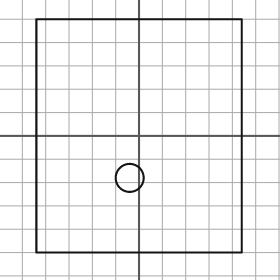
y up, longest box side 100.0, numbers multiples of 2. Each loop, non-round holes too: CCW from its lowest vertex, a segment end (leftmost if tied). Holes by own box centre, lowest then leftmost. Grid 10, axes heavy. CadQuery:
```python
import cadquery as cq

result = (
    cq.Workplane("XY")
    .moveTo(-44.0, -50.0)
    .lineTo(44.0, -50.0)
    .lineTo(44.0, 50.0)
    .lineTo(-44.0, 50.0)
    .close()
    .moveTo(-4.0, -18.0)
    .circle(6.0)
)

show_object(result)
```